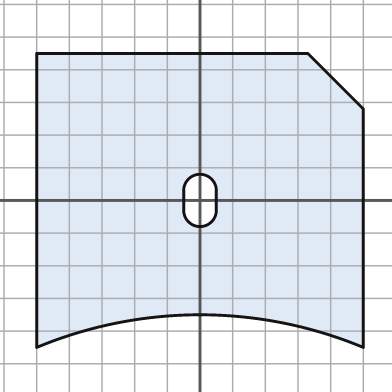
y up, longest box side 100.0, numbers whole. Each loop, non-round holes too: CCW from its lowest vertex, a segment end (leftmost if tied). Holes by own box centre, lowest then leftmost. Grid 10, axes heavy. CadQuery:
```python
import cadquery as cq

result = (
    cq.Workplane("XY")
    .moveTo(-50.0, -45.0)
    .threePointArc((0.0, -35.0), (50.0, -45.0))
    .lineTo(50.0, 28.0)
    .lineTo(33.0, 45.0)
    .lineTo(-50.0, 45.0)
    .close()
    .moveTo(-5.0, -3.0)
    .threePointArc((0.0, -8.0), (5.0, -3.0))
    .lineTo(5.0, 3.0)
    .threePointArc((0.0, 8.0), (-5.0, 3.0))
    .close()
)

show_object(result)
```